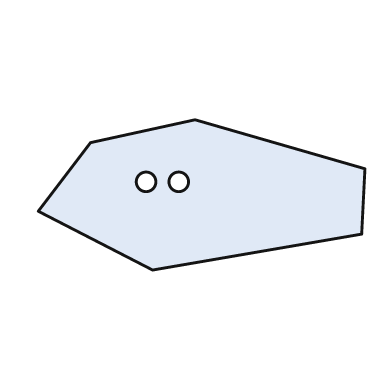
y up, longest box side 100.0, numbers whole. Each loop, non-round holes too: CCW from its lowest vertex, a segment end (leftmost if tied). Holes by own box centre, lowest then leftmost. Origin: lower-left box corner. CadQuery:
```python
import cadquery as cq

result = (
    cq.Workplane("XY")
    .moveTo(35.0, 0.0)
    .lineTo(99.0, 11.0)
    .lineTo(100.0, 31.0)
    .lineTo(48.0, 46.0)
    .lineTo(16.0, 39.0)
    .lineTo(0.0, 18.0)
    .close()
    .moveTo(33.0, 27.0)
    .circle(3.0)
    .moveTo(43.0, 27.0)
    .circle(3.0)
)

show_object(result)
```